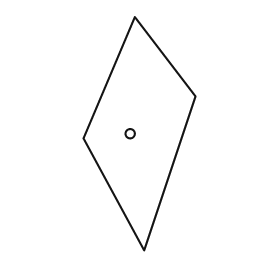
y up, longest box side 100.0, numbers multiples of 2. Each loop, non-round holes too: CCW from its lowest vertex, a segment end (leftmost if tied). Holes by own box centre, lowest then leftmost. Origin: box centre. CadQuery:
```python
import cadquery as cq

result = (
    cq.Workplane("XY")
    .moveTo(2.0, -50.0)
    .lineTo(24.0, 16.0)
    .lineTo(-2.0, 50.0)
    .lineTo(-24.0, -2.0)
    .close()
    .moveTo(-4.0, 0.0)
    .circle(2.0)
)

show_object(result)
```